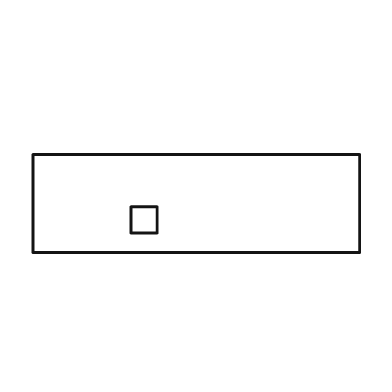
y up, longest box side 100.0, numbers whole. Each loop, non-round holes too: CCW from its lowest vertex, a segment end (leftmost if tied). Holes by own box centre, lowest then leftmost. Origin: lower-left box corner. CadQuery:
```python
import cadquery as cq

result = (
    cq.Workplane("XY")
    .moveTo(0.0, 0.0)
    .lineTo(100.0, 0.0)
    .lineTo(100.0, 30.0)
    .lineTo(0.0, 30.0)
    .close()
    .moveTo(30.0, 6.0)
    .lineTo(38.0, 6.0)
    .lineTo(38.0, 14.0)
    .lineTo(30.0, 14.0)
    .close()
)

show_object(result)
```